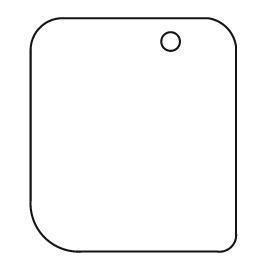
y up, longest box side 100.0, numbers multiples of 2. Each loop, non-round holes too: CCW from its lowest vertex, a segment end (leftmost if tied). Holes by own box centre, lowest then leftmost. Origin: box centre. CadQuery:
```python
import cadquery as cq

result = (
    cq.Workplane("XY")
    .moveTo(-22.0, -50.0)
    .lineTo(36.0, -50.0)
    .threePointArc((42.0, -48.0), (44.0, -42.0))
    .lineTo(44.0, 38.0)
    .threePointArc((40.0, 46.0), (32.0, 50.0))
    .lineTo(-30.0, 50.0)
    .threePointArc((-40.0, 46.0), (-44.0, 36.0))
    .lineTo(-44.0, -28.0)
    .threePointArc((-38.0, -44.0), (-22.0, -50.0))
    .close()
    .moveTo(16.0, 40.0)
    .circle(4.0)
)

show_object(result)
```